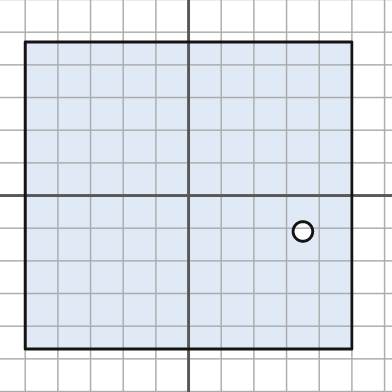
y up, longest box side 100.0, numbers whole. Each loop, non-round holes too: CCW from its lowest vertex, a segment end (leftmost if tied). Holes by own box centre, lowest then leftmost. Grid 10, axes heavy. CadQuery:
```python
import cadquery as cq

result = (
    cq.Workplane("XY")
    .moveTo(-50.0, -47.0)
    .lineTo(50.0, -47.0)
    .lineTo(50.0, 47.0)
    .lineTo(-50.0, 47.0)
    .close()
    .moveTo(35.0, -11.0)
    .circle(3.0)
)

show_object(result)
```